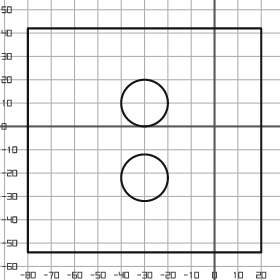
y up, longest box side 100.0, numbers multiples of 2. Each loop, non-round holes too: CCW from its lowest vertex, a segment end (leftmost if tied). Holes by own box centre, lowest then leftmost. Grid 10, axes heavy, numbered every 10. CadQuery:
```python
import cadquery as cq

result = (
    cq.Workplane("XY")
    .moveTo(-80.0, -54.0)
    .lineTo(20.0, -54.0)
    .lineTo(20.0, 42.0)
    .lineTo(-80.0, 42.0)
    .close()
    .moveTo(-30.0, -22.0)
    .circle(10.0)
    .moveTo(-30.0, 10.0)
    .circle(10.0)
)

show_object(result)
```